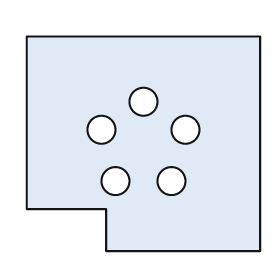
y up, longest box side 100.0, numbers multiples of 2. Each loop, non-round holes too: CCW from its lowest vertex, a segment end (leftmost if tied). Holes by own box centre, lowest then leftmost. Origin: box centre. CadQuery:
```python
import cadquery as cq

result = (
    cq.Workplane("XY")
    .moveTo(-16.0, -46.0)
    .lineTo(50.0, -46.0)
    .lineTo(50.0, 46.0)
    .lineTo(-50.0, 46.0)
    .lineTo(-50.0, -28.0)
    .lineTo(-16.0, -28.0)
    .close()
    .moveTo(-12.0, -16.0)
    .circle(6.0)
    .moveTo(12.0, -16.0)
    .circle(6.0)
    .moveTo(-18.0, 6.0)
    .circle(6.0)
    .moveTo(18.0, 6.0)
    .circle(6.0)
    .moveTo(0.0, 18.0)
    .circle(6.0)
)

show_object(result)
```